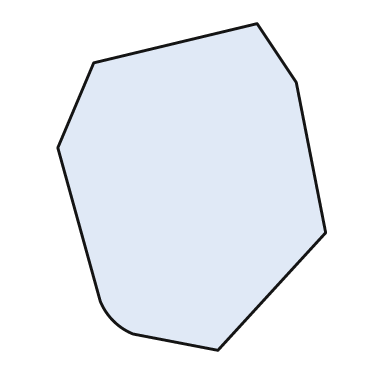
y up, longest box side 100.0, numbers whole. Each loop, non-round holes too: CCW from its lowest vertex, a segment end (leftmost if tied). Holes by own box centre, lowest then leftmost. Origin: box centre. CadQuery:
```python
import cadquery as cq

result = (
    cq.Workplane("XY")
    .moveTo(8.0, -50.0)
    .lineTo(41.0, -14.0)
    .lineTo(32.0, 32.0)
    .lineTo(20.0, 50.0)
    .lineTo(-30.0, 38.0)
    .lineTo(-41.0, 12.0)
    .lineTo(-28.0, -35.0)
    .threePointArc((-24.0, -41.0), (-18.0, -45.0))
    .close()
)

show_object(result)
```